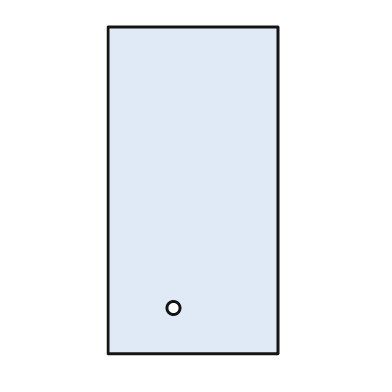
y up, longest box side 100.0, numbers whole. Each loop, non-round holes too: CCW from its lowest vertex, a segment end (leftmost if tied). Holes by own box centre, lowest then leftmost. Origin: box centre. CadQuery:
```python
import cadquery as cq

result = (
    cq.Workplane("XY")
    .moveTo(-26.0, -50.0)
    .lineTo(26.0, -50.0)
    .lineTo(26.0, 50.0)
    .lineTo(-26.0, 50.0)
    .close()
    .moveTo(-6.0, -36.0)
    .circle(2.0)
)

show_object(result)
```